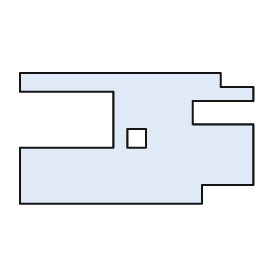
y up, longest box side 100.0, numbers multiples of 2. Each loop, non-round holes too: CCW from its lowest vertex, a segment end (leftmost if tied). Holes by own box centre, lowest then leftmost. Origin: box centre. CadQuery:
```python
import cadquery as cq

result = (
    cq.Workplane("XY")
    .moveTo(-50.0, -28.0)
    .lineTo(28.0, -28.0)
    .lineTo(28.0, -20.0)
    .lineTo(50.0, -20.0)
    .lineTo(50.0, 6.0)
    .lineTo(24.0, 6.0)
    .lineTo(24.0, 16.0)
    .lineTo(50.0, 16.0)
    .lineTo(50.0, 22.0)
    .lineTo(36.0, 22.0)
    .lineTo(36.0, 28.0)
    .lineTo(-50.0, 28.0)
    .lineTo(-50.0, 20.0)
    .lineTo(-10.0, 20.0)
    .lineTo(-10.0, -4.0)
    .lineTo(-50.0, -4.0)
    .close()
    .moveTo(-4.0, -4.0)
    .lineTo(4.0, -4.0)
    .lineTo(4.0, 4.0)
    .lineTo(-4.0, 4.0)
    .close()
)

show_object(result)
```